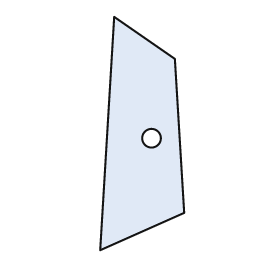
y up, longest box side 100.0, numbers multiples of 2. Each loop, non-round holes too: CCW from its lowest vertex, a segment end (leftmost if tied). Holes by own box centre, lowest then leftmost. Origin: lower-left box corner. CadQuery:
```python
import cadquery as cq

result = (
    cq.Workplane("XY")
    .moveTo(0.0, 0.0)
    .lineTo(36.0, 16.0)
    .lineTo(32.0, 82.0)
    .lineTo(6.0, 100.0)
    .close()
    .moveTo(22.0, 48.0)
    .circle(4.0)
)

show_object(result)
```